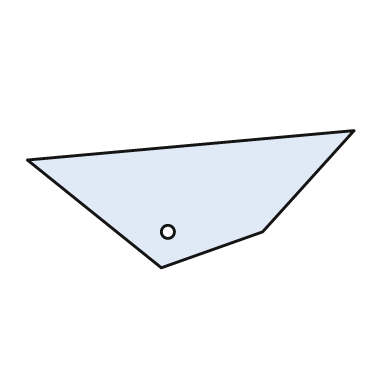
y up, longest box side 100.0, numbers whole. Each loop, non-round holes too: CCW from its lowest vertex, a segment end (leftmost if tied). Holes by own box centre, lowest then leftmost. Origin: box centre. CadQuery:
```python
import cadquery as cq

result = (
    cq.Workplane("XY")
    .moveTo(-9.0, -21.0)
    .lineTo(22.0, -10.0)
    .lineTo(50.0, 21.0)
    .lineTo(-50.0, 12.0)
    .close()
    .moveTo(-7.0, -10.0)
    .circle(2.0)
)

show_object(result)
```